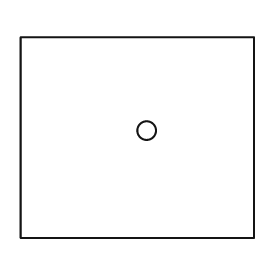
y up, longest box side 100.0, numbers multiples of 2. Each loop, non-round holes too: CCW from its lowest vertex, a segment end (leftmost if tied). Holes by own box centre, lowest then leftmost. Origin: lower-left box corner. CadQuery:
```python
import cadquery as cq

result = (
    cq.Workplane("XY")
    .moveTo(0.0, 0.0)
    .lineTo(100.0, 0.0)
    .lineTo(100.0, 86.0)
    .lineTo(0.0, 86.0)
    .close()
    .moveTo(54.0, 46.0)
    .circle(4.0)
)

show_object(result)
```